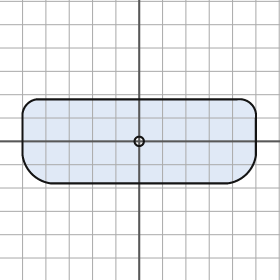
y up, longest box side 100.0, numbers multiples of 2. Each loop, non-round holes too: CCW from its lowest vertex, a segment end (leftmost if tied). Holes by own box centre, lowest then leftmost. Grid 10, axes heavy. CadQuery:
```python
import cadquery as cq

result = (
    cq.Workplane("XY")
    .moveTo(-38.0, -18.0)
    .lineTo(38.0, -18.0)
    .threePointArc((46.0, -14.0), (50.0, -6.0))
    .lineTo(50.0, 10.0)
    .threePointArc((48.0, 16.0), (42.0, 18.0))
    .lineTo(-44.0, 18.0)
    .threePointArc((-48.0, 16.0), (-50.0, 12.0))
    .lineTo(-50.0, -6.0)
    .threePointArc((-46.0, -14.0), (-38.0, -18.0))
    .close()
    .moveTo(0.0, 0.0)
    .circle(2.0)
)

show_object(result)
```